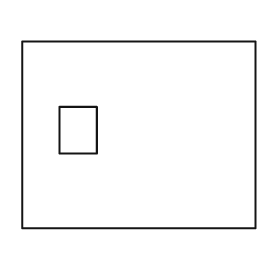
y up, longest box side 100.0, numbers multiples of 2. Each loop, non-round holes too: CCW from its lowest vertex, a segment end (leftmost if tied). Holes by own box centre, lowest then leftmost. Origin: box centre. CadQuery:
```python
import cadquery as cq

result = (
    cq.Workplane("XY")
    .moveTo(-50.0, -40.0)
    .lineTo(50.0, -40.0)
    .lineTo(50.0, 40.0)
    .lineTo(-50.0, 40.0)
    .close()
    .moveTo(-34.0, -8.0)
    .lineTo(-18.0, -8.0)
    .lineTo(-18.0, 12.0)
    .lineTo(-34.0, 12.0)
    .close()
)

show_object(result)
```